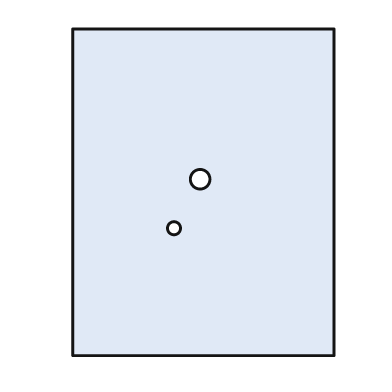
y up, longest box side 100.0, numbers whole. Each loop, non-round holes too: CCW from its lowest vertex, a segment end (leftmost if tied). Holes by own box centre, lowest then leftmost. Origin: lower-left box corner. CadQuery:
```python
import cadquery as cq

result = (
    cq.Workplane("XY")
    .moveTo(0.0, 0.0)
    .lineTo(80.0, 0.0)
    .lineTo(80.0, 100.0)
    .lineTo(0.0, 100.0)
    .close()
    .moveTo(31.0, 39.0)
    .circle(2.0)
    .moveTo(39.0, 54.0)
    .circle(3.0)
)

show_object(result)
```